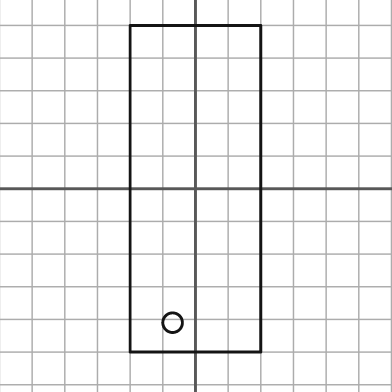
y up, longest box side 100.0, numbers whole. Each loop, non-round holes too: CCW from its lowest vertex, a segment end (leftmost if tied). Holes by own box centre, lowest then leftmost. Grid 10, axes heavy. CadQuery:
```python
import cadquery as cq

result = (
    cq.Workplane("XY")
    .moveTo(-20.0, -50.0)
    .lineTo(20.0, -50.0)
    .lineTo(20.0, 50.0)
    .lineTo(-20.0, 50.0)
    .close()
    .moveTo(-7.0, -41.0)
    .circle(3.0)
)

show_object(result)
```